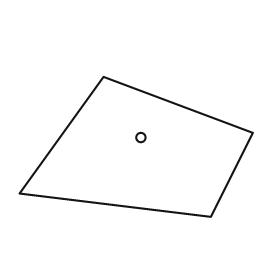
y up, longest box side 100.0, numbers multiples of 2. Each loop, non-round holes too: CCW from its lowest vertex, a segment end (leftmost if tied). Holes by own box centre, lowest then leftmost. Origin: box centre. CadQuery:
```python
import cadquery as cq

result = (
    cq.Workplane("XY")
    .moveTo(32.0, -30.0)
    .lineTo(50.0, 6.0)
    .lineTo(-14.0, 30.0)
    .lineTo(-50.0, -20.0)
    .close()
    .moveTo(2.0, 4.0)
    .circle(2.0)
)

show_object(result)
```